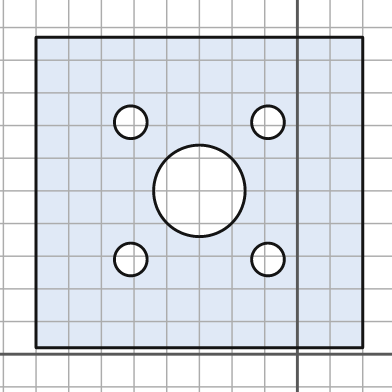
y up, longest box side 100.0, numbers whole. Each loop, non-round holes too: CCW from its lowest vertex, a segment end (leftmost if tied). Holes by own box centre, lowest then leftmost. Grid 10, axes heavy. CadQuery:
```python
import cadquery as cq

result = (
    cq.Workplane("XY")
    .moveTo(-80.0, 2.0)
    .lineTo(20.0, 2.0)
    .lineTo(20.0, 97.0)
    .lineTo(-80.0, 97.0)
    .close()
    .moveTo(-51.0, 29.0)
    .circle(5.0)
    .moveTo(-9.0, 29.0)
    .circle(5.0)
    .moveTo(-30.0, 50.0)
    .circle(14.0)
    .moveTo(-51.0, 71.0)
    .circle(5.0)
    .moveTo(-9.0, 71.0)
    .circle(5.0)
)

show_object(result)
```